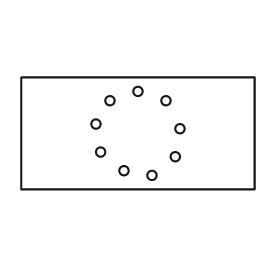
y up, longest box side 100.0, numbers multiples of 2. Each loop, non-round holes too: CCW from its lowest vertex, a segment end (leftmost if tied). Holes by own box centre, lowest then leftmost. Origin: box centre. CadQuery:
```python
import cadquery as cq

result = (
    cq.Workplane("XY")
    .moveTo(-50.0, -24.0)
    .lineTo(50.0, -24.0)
    .lineTo(50.0, 24.0)
    .lineTo(-50.0, 24.0)
    .close()
    .moveTo(6.0, -18.0)
    .circle(2.0)
    .moveTo(-6.0, -16.0)
    .circle(2.0)
    .moveTo(16.0, -10.0)
    .circle(2.0)
    .moveTo(-16.0, -8.0)
    .circle(2.0)
    .moveTo(18.0, 2.0)
    .circle(2.0)
    .moveTo(-18.0, 4.0)
    .circle(2.0)
    .moveTo(-12.0, 14.0)
    .circle(2.0)
    .moveTo(12.0, 14.0)
    .circle(2.0)
    .moveTo(0.0, 18.0)
    .circle(2.0)
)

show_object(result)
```